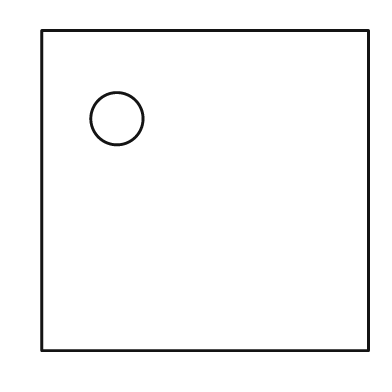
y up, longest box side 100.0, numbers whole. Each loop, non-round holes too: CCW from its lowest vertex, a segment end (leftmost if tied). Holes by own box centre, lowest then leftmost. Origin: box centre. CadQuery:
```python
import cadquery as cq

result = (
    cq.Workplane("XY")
    .moveTo(-50.0, -49.0)
    .lineTo(50.0, -49.0)
    .lineTo(50.0, 49.0)
    .lineTo(-50.0, 49.0)
    .close()
    .moveTo(-27.0, 22.0)
    .circle(8.0)
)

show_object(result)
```